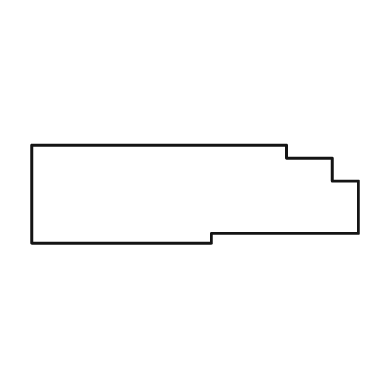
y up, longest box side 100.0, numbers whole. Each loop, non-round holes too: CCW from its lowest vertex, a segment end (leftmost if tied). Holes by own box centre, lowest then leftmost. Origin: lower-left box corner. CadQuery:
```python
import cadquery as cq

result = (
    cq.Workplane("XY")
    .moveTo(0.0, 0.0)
    .lineTo(55.0, 0.0)
    .lineTo(55.0, 3.0)
    .lineTo(100.0, 3.0)
    .lineTo(100.0, 19.0)
    .lineTo(92.0, 19.0)
    .lineTo(92.0, 26.0)
    .lineTo(78.0, 26.0)
    .lineTo(78.0, 30.0)
    .lineTo(0.0, 30.0)
    .close()
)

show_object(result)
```